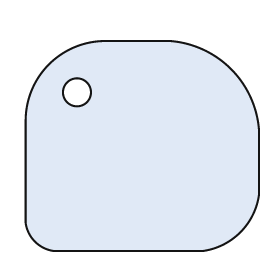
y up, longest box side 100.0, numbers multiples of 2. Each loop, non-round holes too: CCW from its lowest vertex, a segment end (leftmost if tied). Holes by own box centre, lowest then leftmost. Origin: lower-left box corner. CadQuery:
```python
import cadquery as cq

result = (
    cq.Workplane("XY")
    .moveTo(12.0, 0.0)
    .lineTo(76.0, 0.0)
    .threePointArc((92.0, 8.0), (100.0, 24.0))
    .lineTo(100.0, 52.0)
    .threePointArc((88.0, 78.0), (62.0, 90.0))
    .lineTo(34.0, 90.0)
    .threePointArc((10.0, 80.0), (0.0, 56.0))
    .lineTo(0.0, 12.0)
    .threePointArc((4.0, 4.0), (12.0, 0.0))
    .close()
    .moveTo(22.0, 68.0)
    .circle(6.0)
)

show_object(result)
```